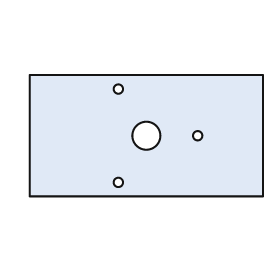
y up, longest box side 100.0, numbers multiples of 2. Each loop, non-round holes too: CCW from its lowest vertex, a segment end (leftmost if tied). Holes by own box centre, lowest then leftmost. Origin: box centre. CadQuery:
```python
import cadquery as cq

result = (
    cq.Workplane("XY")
    .moveTo(-50.0, -26.0)
    .lineTo(50.0, -26.0)
    .lineTo(50.0, 26.0)
    .lineTo(-50.0, 26.0)
    .close()
    .moveTo(-12.0, -20.0)
    .circle(2.0)
    .moveTo(0.0, 0.0)
    .circle(6.0)
    .moveTo(22.0, 0.0)
    .circle(2.0)
    .moveTo(-12.0, 20.0)
    .circle(2.0)
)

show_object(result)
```